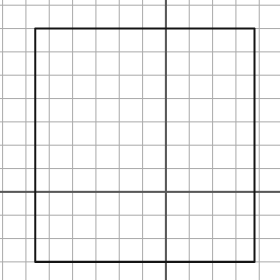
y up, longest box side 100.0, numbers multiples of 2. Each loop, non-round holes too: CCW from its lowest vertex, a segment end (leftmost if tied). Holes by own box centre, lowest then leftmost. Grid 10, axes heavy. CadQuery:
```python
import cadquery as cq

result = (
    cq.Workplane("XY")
    .moveTo(-56.0, -30.0)
    .lineTo(38.0, -30.0)
    .lineTo(38.0, 70.0)
    .lineTo(-56.0, 70.0)
    .close()
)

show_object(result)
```